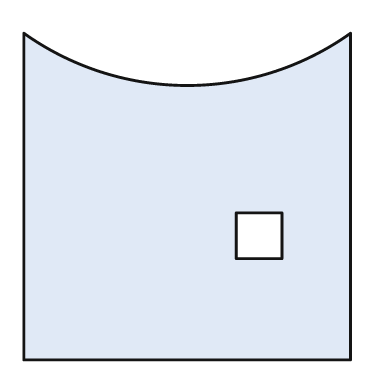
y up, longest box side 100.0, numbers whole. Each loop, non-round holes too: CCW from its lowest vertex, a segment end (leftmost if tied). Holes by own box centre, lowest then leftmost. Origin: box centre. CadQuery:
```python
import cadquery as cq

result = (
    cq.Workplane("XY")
    .moveTo(-50.0, -50.0)
    .lineTo(50.0, -50.0)
    .lineTo(50.0, 50.0)
    .threePointArc((0.0, 34.0), (-50.0, 50.0))
    .close()
    .moveTo(15.0, -19.0)
    .lineTo(29.0, -19.0)
    .lineTo(29.0, -5.0)
    .lineTo(15.0, -5.0)
    .close()
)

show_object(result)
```